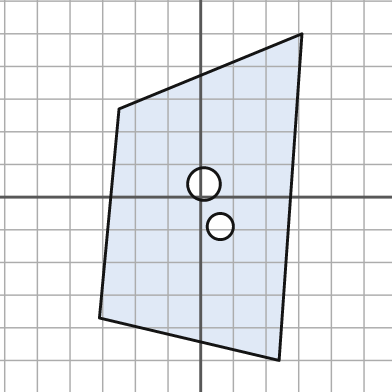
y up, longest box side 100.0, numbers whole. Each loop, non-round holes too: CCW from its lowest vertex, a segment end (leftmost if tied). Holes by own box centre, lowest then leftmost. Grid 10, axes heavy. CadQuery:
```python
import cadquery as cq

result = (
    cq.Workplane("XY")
    .moveTo(24.0, -50.0)
    .lineTo(31.0, 50.0)
    .lineTo(-25.0, 27.0)
    .lineTo(-31.0, -37.0)
    .close()
    .moveTo(6.0, -9.0)
    .circle(4.0)
    .moveTo(1.0, 4.0)
    .circle(5.0)
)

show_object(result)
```